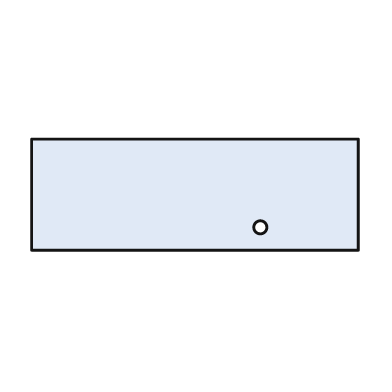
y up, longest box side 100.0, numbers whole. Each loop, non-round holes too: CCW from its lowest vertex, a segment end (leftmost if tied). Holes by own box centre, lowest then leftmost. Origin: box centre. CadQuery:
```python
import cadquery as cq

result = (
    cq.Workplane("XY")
    .moveTo(-50.0, -17.0)
    .lineTo(50.0, -17.0)
    .lineTo(50.0, 17.0)
    .lineTo(-50.0, 17.0)
    .close()
    .moveTo(20.0, -10.0)
    .circle(2.0)
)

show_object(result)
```